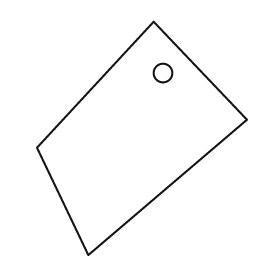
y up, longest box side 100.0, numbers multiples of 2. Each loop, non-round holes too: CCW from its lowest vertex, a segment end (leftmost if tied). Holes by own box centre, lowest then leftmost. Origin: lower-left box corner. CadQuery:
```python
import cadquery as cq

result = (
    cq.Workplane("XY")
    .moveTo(22.0, 0.0)
    .lineTo(90.0, 58.0)
    .lineTo(50.0, 100.0)
    .lineTo(0.0, 46.0)
    .close()
    .moveTo(54.0, 78.0)
    .circle(4.0)
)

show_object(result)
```